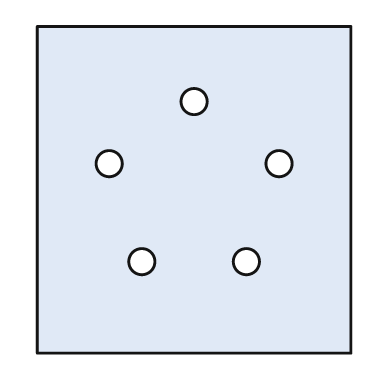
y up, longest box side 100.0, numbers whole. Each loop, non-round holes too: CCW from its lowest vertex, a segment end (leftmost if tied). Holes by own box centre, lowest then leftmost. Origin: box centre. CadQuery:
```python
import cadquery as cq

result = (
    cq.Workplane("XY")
    .moveTo(-48.0, -50.0)
    .lineTo(48.0, -50.0)
    .lineTo(48.0, 50.0)
    .lineTo(-48.0, 50.0)
    .close()
    .moveTo(-16.0, -22.0)
    .circle(4.0)
    .moveTo(16.0, -22.0)
    .circle(4.0)
    .moveTo(-26.0, 8.0)
    .circle(4.0)
    .moveTo(26.0, 8.0)
    .circle(4.0)
    .moveTo(0.0, 27.0)
    .circle(4.0)
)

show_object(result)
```